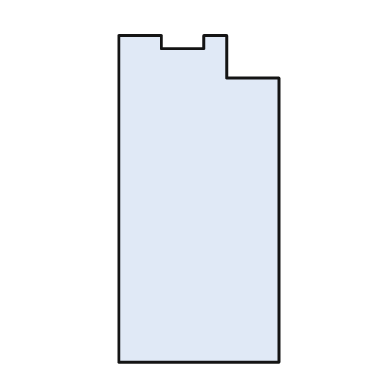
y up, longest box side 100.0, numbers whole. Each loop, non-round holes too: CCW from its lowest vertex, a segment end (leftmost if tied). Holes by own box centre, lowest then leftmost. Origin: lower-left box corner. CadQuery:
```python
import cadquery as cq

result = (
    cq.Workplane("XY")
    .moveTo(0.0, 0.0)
    .lineTo(49.0, 0.0)
    .lineTo(49.0, 87.0)
    .lineTo(33.0, 87.0)
    .lineTo(33.0, 100.0)
    .lineTo(26.0, 100.0)
    .lineTo(26.0, 96.0)
    .lineTo(13.0, 96.0)
    .lineTo(13.0, 100.0)
    .lineTo(0.0, 100.0)
    .close()
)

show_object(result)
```